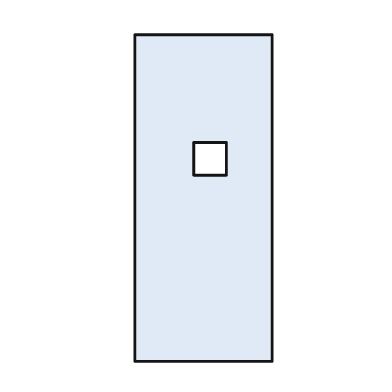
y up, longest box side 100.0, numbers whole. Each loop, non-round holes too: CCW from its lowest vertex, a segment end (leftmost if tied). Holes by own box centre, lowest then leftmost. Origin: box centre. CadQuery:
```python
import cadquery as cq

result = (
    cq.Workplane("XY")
    .moveTo(-21.0, -50.0)
    .lineTo(21.0, -50.0)
    .lineTo(21.0, 50.0)
    .lineTo(-21.0, 50.0)
    .close()
    .moveTo(-3.0, 7.0)
    .lineTo(7.0, 7.0)
    .lineTo(7.0, 17.0)
    .lineTo(-3.0, 17.0)
    .close()
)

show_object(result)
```